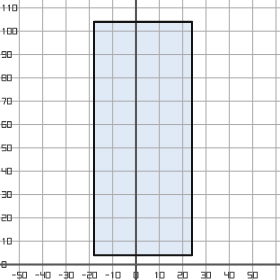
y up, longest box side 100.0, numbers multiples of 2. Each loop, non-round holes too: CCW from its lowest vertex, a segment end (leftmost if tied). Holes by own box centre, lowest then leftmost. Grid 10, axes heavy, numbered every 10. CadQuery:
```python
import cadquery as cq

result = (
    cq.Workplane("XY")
    .moveTo(-18.0, 4.0)
    .lineTo(24.0, 4.0)
    .lineTo(24.0, 104.0)
    .lineTo(-18.0, 104.0)
    .close()
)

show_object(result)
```